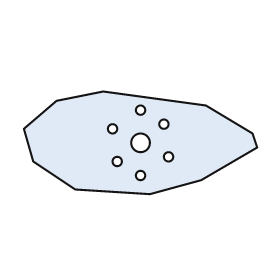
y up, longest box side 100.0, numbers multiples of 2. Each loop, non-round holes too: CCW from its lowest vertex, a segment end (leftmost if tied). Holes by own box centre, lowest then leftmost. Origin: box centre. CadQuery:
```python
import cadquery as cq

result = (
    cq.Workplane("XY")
    .moveTo(4.0, -22.0)
    .lineTo(26.0, -16.0)
    .lineTo(50.0, -2.0)
    .lineTo(48.0, 4.0)
    .lineTo(28.0, 16.0)
    .lineTo(-16.0, 22.0)
    .lineTo(-36.0, 18.0)
    .lineTo(-50.0, 6.0)
    .lineTo(-46.0, -8.0)
    .lineTo(-28.0, -20.0)
    .close()
    .moveTo(0.0, -14.0)
    .circle(2.0)
    .moveTo(-10.0, -8.0)
    .circle(2.0)
    .moveTo(12.0, -6.0)
    .circle(2.0)
    .moveTo(0.0, 0.0)
    .circle(4.0)
    .moveTo(-12.0, 6.0)
    .circle(2.0)
    .moveTo(10.0, 8.0)
    .circle(2.0)
    .moveTo(0.0, 14.0)
    .circle(2.0)
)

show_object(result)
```